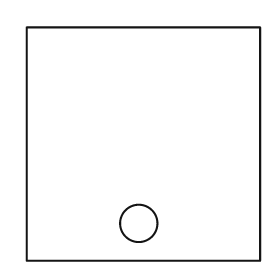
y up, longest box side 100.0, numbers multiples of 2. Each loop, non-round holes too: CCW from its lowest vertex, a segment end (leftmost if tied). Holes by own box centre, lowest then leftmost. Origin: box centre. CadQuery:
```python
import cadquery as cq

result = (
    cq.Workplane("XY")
    .moveTo(-50.0, -50.0)
    .lineTo(50.0, -50.0)
    .lineTo(50.0, 50.0)
    .lineTo(-50.0, 50.0)
    .close()
    .moveTo(-2.0, -34.0)
    .circle(8.0)
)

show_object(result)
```